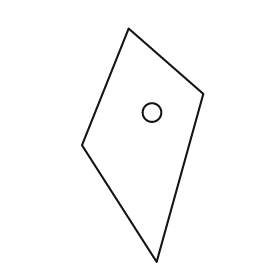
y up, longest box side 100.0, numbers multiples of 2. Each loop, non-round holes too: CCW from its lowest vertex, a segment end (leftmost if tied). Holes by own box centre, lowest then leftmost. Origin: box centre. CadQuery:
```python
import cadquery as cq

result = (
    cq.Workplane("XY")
    .moveTo(6.0, -50.0)
    .lineTo(26.0, 22.0)
    .lineTo(-6.0, 50.0)
    .lineTo(-26.0, 0.0)
    .close()
    .moveTo(4.0, 14.0)
    .circle(4.0)
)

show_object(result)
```